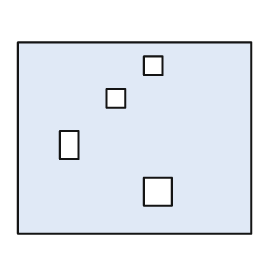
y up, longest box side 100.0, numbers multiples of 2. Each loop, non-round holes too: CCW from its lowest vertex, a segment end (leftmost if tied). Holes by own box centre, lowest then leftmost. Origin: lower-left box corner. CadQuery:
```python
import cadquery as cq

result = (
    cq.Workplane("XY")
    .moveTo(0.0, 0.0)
    .lineTo(100.0, 0.0)
    .lineTo(100.0, 82.0)
    .lineTo(0.0, 82.0)
    .close()
    .moveTo(54.0, 12.0)
    .lineTo(66.0, 12.0)
    .lineTo(66.0, 24.0)
    .lineTo(54.0, 24.0)
    .close()
    .moveTo(18.0, 32.0)
    .lineTo(26.0, 32.0)
    .lineTo(26.0, 44.0)
    .lineTo(18.0, 44.0)
    .close()
    .moveTo(38.0, 54.0)
    .lineTo(46.0, 54.0)
    .lineTo(46.0, 62.0)
    .lineTo(38.0, 62.0)
    .close()
    .moveTo(54.0, 68.0)
    .lineTo(62.0, 68.0)
    .lineTo(62.0, 76.0)
    .lineTo(54.0, 76.0)
    .close()
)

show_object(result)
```